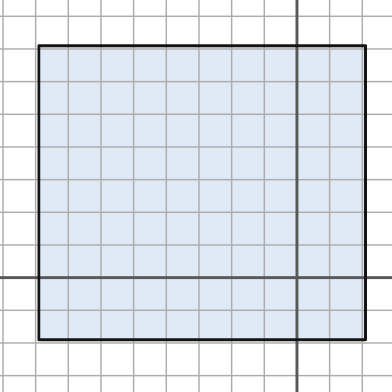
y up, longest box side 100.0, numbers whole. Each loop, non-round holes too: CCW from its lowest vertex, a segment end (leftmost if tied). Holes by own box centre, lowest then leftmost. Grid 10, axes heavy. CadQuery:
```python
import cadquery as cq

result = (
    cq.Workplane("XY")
    .moveTo(-79.0, -19.0)
    .lineTo(21.0, -19.0)
    .lineTo(21.0, 71.0)
    .lineTo(-79.0, 71.0)
    .close()
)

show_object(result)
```